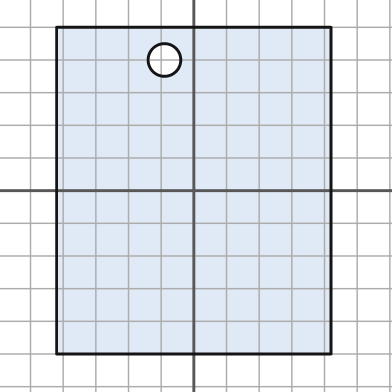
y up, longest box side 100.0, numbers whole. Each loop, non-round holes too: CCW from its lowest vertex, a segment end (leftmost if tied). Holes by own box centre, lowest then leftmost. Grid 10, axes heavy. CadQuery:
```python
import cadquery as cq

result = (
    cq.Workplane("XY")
    .moveTo(-42.0, -50.0)
    .lineTo(42.0, -50.0)
    .lineTo(42.0, 50.0)
    .lineTo(-42.0, 50.0)
    .close()
    .moveTo(-9.0, 40.0)
    .circle(5.0)
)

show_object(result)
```